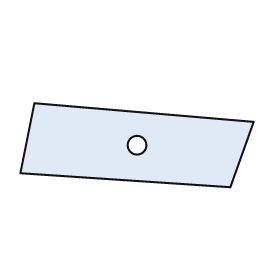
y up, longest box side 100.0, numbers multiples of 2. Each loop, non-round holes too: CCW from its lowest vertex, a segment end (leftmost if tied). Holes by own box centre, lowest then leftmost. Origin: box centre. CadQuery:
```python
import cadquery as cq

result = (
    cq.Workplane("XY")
    .moveTo(40.0, -18.0)
    .lineTo(50.0, 10.0)
    .lineTo(-44.0, 18.0)
    .lineTo(-50.0, -12.0)
    .close()
    .moveTo(0.0, 0.0)
    .circle(4.0)
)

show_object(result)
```